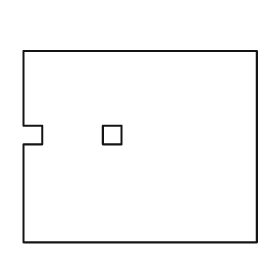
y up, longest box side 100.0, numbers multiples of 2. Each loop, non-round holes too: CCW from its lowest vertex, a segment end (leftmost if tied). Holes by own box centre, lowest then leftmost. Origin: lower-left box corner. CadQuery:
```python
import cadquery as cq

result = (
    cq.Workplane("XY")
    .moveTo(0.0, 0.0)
    .lineTo(100.0, 0.0)
    .lineTo(100.0, 82.0)
    .lineTo(0.0, 82.0)
    .lineTo(0.0, 50.0)
    .lineTo(8.0, 50.0)
    .lineTo(8.0, 42.0)
    .lineTo(0.0, 42.0)
    .close()
    .moveTo(34.0, 42.0)
    .lineTo(42.0, 42.0)
    .lineTo(42.0, 50.0)
    .lineTo(34.0, 50.0)
    .close()
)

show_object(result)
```